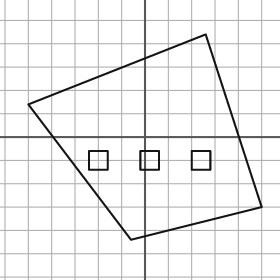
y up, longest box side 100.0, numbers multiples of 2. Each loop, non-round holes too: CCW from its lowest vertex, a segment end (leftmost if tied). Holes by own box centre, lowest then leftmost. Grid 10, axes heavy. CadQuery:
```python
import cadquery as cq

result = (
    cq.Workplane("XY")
    .moveTo(-6.0, -44.0)
    .lineTo(50.0, -30.0)
    .lineTo(26.0, 44.0)
    .lineTo(-50.0, 14.0)
    .close()
    .moveTo(-24.0, -14.0)
    .lineTo(-16.0, -14.0)
    .lineTo(-16.0, -6.0)
    .lineTo(-24.0, -6.0)
    .close()
    .moveTo(-2.0, -14.0)
    .lineTo(6.0, -14.0)
    .lineTo(6.0, -6.0)
    .lineTo(-2.0, -6.0)
    .close()
    .moveTo(20.0, -14.0)
    .lineTo(28.0, -14.0)
    .lineTo(28.0, -6.0)
    .lineTo(20.0, -6.0)
    .close()
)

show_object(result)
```